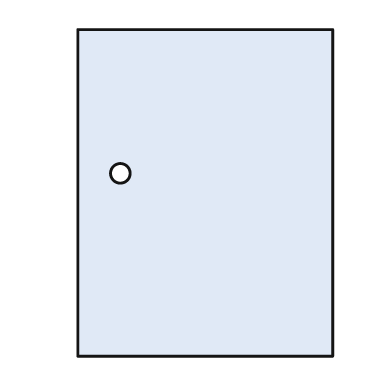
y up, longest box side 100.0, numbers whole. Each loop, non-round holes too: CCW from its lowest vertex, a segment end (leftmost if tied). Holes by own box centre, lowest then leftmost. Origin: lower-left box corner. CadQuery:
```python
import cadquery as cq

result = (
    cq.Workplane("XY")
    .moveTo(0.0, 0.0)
    .lineTo(78.0, 0.0)
    .lineTo(78.0, 100.0)
    .lineTo(0.0, 100.0)
    .close()
    .moveTo(13.0, 56.0)
    .circle(3.0)
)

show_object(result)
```